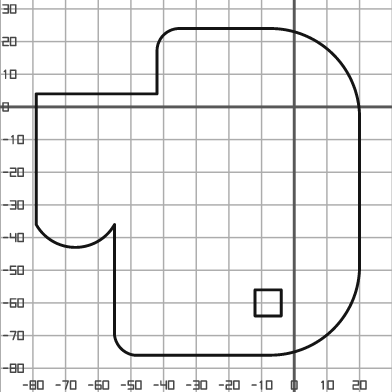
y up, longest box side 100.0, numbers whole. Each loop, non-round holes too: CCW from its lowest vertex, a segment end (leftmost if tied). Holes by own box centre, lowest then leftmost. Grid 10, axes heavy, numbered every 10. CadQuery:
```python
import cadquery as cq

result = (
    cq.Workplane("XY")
    .moveTo(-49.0, -76.0)
    .lineTo(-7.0, -76.0)
    .threePointArc((12.0, -68.0), (20.0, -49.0))
    .lineTo(20.0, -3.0)
    .threePointArc((12.0, 16.0), (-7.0, 24.0))
    .lineTo(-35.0, 24.0)
    .threePointArc((-40.0, 22.0), (-42.0, 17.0))
    .lineTo(-42.0, 4.0)
    .lineTo(-79.0, 4.0)
    .lineTo(-79.0, -36.0)
    .threePointArc((-67.0, -43.0), (-55.0, -36.0))
    .lineTo(-55.0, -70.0)
    .threePointArc((-53.0, -74.0), (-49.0, -76.0))
    .close()
    .moveTo(-12.0, -64.0)
    .lineTo(-4.0, -64.0)
    .lineTo(-4.0, -56.0)
    .lineTo(-12.0, -56.0)
    .close()
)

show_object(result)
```